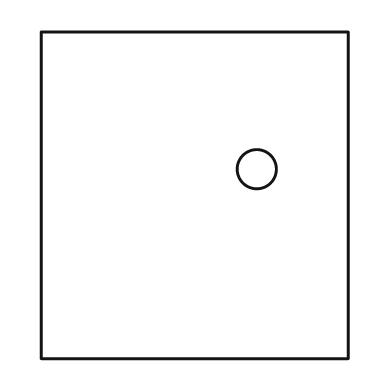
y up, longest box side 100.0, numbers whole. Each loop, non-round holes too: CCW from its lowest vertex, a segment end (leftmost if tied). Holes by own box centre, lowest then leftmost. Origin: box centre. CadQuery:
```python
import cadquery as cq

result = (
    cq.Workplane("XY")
    .moveTo(-47.0, -50.0)
    .lineTo(47.0, -50.0)
    .lineTo(47.0, 50.0)
    .lineTo(-47.0, 50.0)
    .close()
    .moveTo(19.0, 8.0)
    .circle(6.0)
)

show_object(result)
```